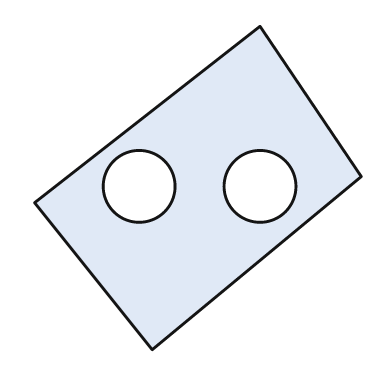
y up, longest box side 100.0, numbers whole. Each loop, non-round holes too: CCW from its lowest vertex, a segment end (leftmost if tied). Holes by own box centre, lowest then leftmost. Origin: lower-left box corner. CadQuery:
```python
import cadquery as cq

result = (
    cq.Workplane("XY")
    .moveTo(36.0, 0.0)
    .lineTo(100.0, 53.0)
    .lineTo(69.0, 99.0)
    .lineTo(0.0, 45.0)
    .close()
    .moveTo(32.0, 50.0)
    .circle(11.0)
    .moveTo(69.0, 50.0)
    .circle(11.0)
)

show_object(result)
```